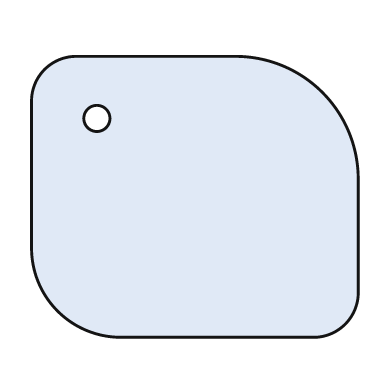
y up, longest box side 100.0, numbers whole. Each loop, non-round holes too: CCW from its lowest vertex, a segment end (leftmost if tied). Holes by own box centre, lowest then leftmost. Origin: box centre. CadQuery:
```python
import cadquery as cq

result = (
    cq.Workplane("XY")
    .moveTo(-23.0, -43.0)
    .lineTo(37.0, -43.0)
    .threePointArc((46.0, -39.0), (50.0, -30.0))
    .lineTo(50.0, 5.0)
    .threePointArc((39.0, 32.0), (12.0, 43.0))
    .lineTo(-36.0, 43.0)
    .threePointArc((-46.0, 39.0), (-50.0, 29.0))
    .lineTo(-50.0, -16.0)
    .threePointArc((-42.0, -35.0), (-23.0, -43.0))
    .close()
    .moveTo(-30.0, 24.0)
    .circle(4.0)
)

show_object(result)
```